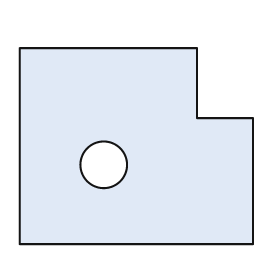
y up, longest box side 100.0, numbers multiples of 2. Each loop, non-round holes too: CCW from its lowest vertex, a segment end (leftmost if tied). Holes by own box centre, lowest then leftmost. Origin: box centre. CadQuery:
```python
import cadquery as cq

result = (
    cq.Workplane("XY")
    .moveTo(-50.0, -42.0)
    .lineTo(50.0, -42.0)
    .lineTo(50.0, 12.0)
    .lineTo(26.0, 12.0)
    .lineTo(26.0, 42.0)
    .lineTo(-50.0, 42.0)
    .close()
    .moveTo(-14.0, -8.0)
    .circle(10.0)
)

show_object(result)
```